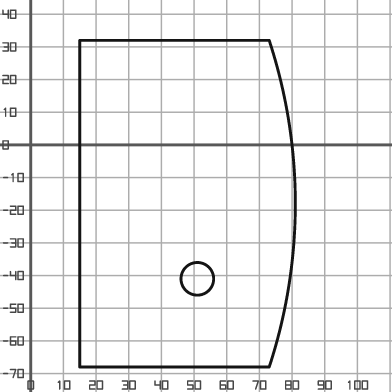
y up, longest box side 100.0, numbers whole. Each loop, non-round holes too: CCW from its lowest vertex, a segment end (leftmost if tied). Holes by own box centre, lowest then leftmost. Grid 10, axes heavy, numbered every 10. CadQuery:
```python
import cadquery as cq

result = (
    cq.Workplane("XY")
    .moveTo(15.0, -68.0)
    .lineTo(73.0, -68.0)
    .threePointArc((81.0, -18.0), (73.0, 32.0))
    .lineTo(15.0, 32.0)
    .close()
    .moveTo(51.0, -41.0)
    .circle(5.0)
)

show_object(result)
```